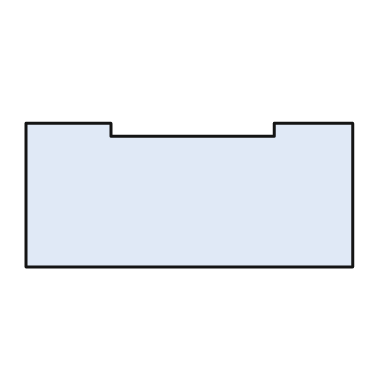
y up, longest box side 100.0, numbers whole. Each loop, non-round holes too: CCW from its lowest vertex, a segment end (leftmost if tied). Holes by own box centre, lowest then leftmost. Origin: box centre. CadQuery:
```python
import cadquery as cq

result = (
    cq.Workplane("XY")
    .moveTo(-50.0, -22.0)
    .lineTo(50.0, -22.0)
    .lineTo(50.0, 22.0)
    .lineTo(26.0, 22.0)
    .lineTo(26.0, 18.0)
    .lineTo(-24.0, 18.0)
    .lineTo(-24.0, 22.0)
    .lineTo(-50.0, 22.0)
    .close()
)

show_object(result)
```